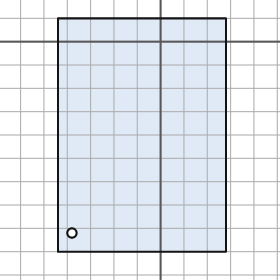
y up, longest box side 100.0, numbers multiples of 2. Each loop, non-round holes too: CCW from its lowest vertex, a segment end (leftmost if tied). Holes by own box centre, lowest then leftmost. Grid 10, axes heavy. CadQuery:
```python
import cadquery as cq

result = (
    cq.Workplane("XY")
    .moveTo(-44.0, -90.0)
    .lineTo(28.0, -90.0)
    .lineTo(28.0, 10.0)
    .lineTo(-44.0, 10.0)
    .close()
    .moveTo(-38.0, -82.0)
    .circle(2.0)
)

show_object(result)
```